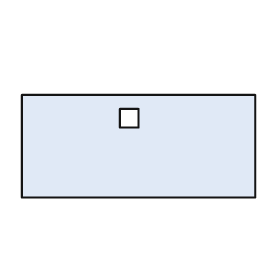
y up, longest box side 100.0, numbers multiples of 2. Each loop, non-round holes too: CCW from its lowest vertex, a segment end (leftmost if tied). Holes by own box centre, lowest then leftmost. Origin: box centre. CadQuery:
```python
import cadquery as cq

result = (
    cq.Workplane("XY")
    .moveTo(-50.0, -22.0)
    .lineTo(50.0, -22.0)
    .lineTo(50.0, 22.0)
    .lineTo(-50.0, 22.0)
    .close()
    .moveTo(-8.0, 8.0)
    .lineTo(0.0, 8.0)
    .lineTo(0.0, 16.0)
    .lineTo(-8.0, 16.0)
    .close()
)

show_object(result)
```